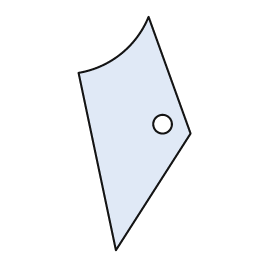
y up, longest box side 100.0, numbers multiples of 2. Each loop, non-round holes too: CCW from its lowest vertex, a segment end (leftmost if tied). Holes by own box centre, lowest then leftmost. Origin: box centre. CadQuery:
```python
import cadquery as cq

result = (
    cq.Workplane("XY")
    .moveTo(-8.0, -50.0)
    .lineTo(24.0, 0.0)
    .lineTo(6.0, 50.0)
    .threePointArc((-6.0, 34.0), (-24.0, 26.0))
    .close()
    .moveTo(12.0, 4.0)
    .circle(4.0)
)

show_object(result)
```